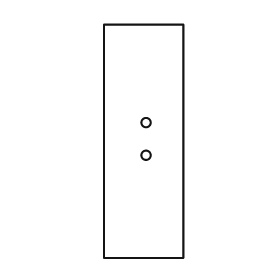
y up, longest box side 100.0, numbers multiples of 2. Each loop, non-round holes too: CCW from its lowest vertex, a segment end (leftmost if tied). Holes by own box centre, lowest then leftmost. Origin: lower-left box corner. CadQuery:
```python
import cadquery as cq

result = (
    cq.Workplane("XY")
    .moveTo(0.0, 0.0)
    .lineTo(34.0, 0.0)
    .lineTo(34.0, 100.0)
    .lineTo(0.0, 100.0)
    .close()
    .moveTo(18.0, 44.0)
    .circle(2.0)
    .moveTo(18.0, 58.0)
    .circle(2.0)
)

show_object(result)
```